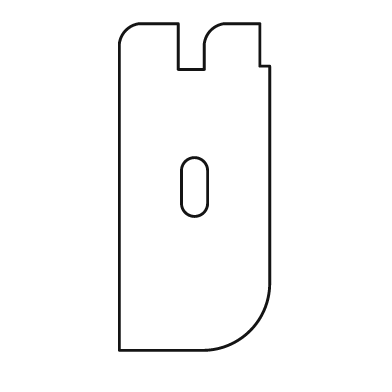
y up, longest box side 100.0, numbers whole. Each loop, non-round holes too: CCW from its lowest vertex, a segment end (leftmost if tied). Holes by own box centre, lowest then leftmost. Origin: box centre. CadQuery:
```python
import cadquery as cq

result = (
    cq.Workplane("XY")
    .moveTo(-23.0, -50.0)
    .lineTo(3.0, -50.0)
    .threePointArc((17.0, -44.0), (23.0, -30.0))
    .lineTo(23.0, 37.0)
    .lineTo(20.0, 37.0)
    .lineTo(20.0, 50.0)
    .lineTo(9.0, 50.0)
    .threePointArc((5.0, 48.0), (3.0, 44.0))
    .lineTo(3.0, 36.0)
    .lineTo(-5.0, 36.0)
    .lineTo(-5.0, 50.0)
    .lineTo(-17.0, 50.0)
    .threePointArc((-21.0, 48.0), (-23.0, 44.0))
    .close()
    .moveTo(-4.0, -5.0)
    .threePointArc((0.0, -9.0), (4.0, -5.0))
    .lineTo(4.0, 5.0)
    .threePointArc((0.0, 9.0), (-4.0, 5.0))
    .close()
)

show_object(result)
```